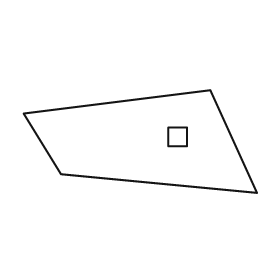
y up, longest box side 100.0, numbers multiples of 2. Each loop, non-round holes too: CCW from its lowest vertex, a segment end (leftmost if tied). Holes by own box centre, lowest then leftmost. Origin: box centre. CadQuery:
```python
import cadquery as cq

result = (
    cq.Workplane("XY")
    .moveTo(50.0, -22.0)
    .lineTo(30.0, 22.0)
    .lineTo(-50.0, 12.0)
    .lineTo(-34.0, -14.0)
    .close()
    .moveTo(12.0, -2.0)
    .lineTo(20.0, -2.0)
    .lineTo(20.0, 6.0)
    .lineTo(12.0, 6.0)
    .close()
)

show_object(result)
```